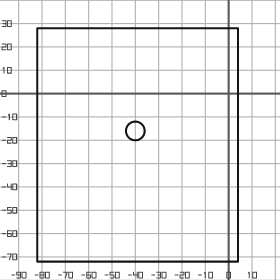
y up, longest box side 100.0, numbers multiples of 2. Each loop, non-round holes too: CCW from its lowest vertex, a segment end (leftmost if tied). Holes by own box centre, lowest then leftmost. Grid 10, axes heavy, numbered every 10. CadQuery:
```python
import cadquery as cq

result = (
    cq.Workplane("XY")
    .moveTo(-82.0, -72.0)
    .lineTo(4.0, -72.0)
    .lineTo(4.0, 28.0)
    .lineTo(-82.0, 28.0)
    .close()
    .moveTo(-40.0, -16.0)
    .circle(4.0)
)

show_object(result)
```